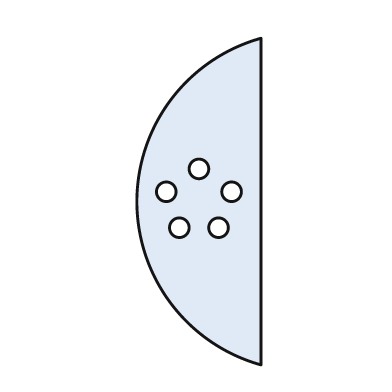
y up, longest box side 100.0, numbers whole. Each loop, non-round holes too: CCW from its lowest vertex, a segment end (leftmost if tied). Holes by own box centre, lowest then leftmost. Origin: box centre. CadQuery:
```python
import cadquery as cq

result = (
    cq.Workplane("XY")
    .moveTo(19.0, -50.0)
    .lineTo(19.0, 50.0)
    .threePointArc((-19.0, 0.0), (19.0, -50.0))
    .close()
    .moveTo(-6.0, -8.0)
    .circle(3.0)
    .moveTo(6.0, -8.0)
    .circle(3.0)
    .moveTo(-10.0, 3.0)
    .circle(3.0)
    .moveTo(10.0, 3.0)
    .circle(3.0)
    .moveTo(0.0, 10.0)
    .circle(3.0)
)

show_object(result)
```